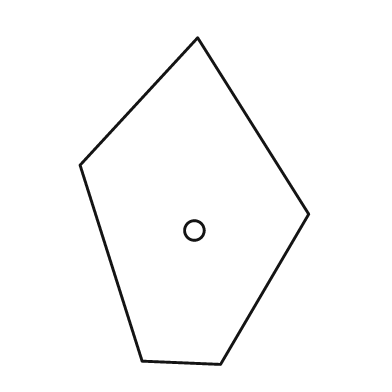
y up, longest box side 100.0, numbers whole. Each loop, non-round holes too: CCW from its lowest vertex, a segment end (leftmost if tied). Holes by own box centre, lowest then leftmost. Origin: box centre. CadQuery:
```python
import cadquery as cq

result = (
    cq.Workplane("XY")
    .moveTo(8.0, -50.0)
    .lineTo(35.0, -4.0)
    .lineTo(1.0, 50.0)
    .lineTo(-35.0, 11.0)
    .lineTo(-16.0, -49.0)
    .close()
    .moveTo(0.0, -9.0)
    .circle(3.0)
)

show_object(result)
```